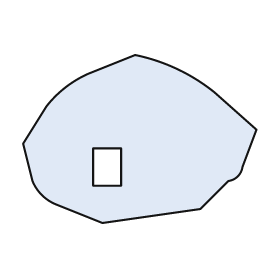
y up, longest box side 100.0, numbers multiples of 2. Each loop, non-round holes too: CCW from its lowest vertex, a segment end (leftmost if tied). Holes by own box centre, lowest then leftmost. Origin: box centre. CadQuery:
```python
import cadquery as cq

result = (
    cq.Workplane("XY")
    .moveTo(-16.0, -36.0)
    .lineTo(26.0, -30.0)
    .lineTo(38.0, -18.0)
    .threePointArc((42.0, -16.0), (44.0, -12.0))
    .lineTo(50.0, 4.0)
    .lineTo(32.0, 20.0)
    .threePointArc((16.0, 30.0), (-2.0, 36.0))
    .lineTo(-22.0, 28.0)
    .threePointArc((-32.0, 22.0), (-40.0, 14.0))
    .lineTo(-50.0, -2.0)
    .lineTo(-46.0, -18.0)
    .threePointArc((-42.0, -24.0), (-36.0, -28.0))
    .close()
    .moveTo(-20.0, -20.0)
    .lineTo(-8.0, -20.0)
    .lineTo(-8.0, -4.0)
    .lineTo(-20.0, -4.0)
    .close()
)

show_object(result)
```